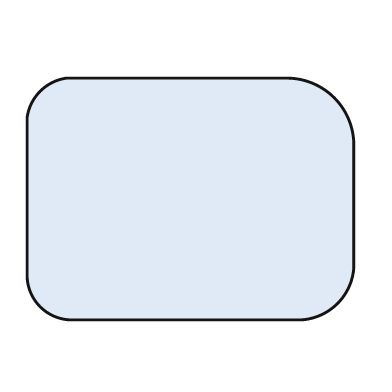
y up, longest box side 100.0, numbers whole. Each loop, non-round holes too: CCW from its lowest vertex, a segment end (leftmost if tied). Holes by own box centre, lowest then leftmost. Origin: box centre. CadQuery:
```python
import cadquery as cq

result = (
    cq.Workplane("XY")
    .moveTo(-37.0, -37.0)
    .lineTo(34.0, -37.0)
    .threePointArc((45.0, -32.0), (50.0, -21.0))
    .lineTo(50.0, 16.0)
    .threePointArc((44.0, 31.0), (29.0, 37.0))
    .lineTo(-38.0, 37.0)
    .threePointArc((-46.0, 33.0), (-50.0, 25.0))
    .lineTo(-50.0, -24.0)
    .threePointArc((-46.0, -33.0), (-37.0, -37.0))
    .close()
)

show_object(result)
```